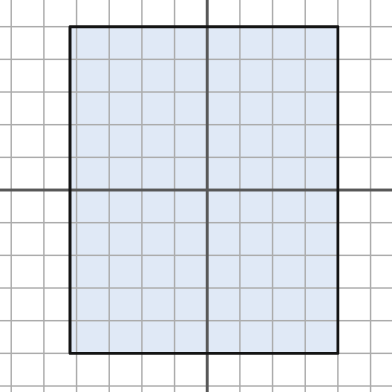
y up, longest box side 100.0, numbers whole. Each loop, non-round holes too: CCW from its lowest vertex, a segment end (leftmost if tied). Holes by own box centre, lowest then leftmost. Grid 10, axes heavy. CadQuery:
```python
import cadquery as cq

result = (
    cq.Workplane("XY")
    .moveTo(-42.0, -50.0)
    .lineTo(40.0, -50.0)
    .lineTo(40.0, 50.0)
    .lineTo(-42.0, 50.0)
    .close()
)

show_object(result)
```